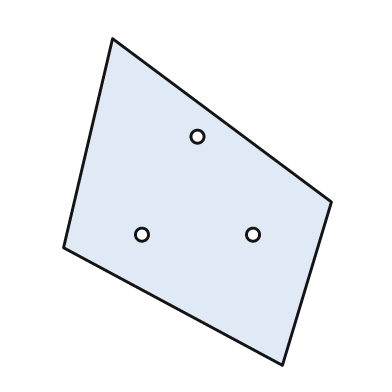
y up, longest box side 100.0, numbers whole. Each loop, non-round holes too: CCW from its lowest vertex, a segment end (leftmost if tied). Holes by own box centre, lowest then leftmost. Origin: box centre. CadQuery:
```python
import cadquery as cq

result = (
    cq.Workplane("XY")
    .moveTo(26.0, -50.0)
    .lineTo(41.0, 0.0)
    .lineTo(-26.0, 50.0)
    .lineTo(-41.0, -14.0)
    .close()
    .moveTo(-17.0, -10.0)
    .circle(2.0)
    .moveTo(17.0, -10.0)
    .circle(2.0)
    .moveTo(0.0, 20.0)
    .circle(2.0)
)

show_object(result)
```